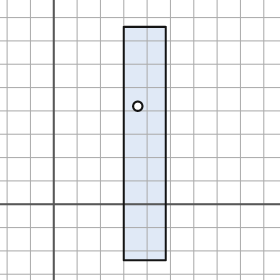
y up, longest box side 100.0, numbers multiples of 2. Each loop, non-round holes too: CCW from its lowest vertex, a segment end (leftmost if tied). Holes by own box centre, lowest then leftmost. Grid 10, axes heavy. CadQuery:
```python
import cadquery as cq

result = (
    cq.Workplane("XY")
    .moveTo(30.0, -24.0)
    .lineTo(48.0, -24.0)
    .lineTo(48.0, 76.0)
    .lineTo(30.0, 76.0)
    .close()
    .moveTo(36.0, 42.0)
    .circle(2.0)
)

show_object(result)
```